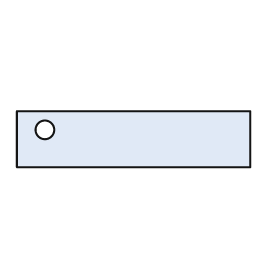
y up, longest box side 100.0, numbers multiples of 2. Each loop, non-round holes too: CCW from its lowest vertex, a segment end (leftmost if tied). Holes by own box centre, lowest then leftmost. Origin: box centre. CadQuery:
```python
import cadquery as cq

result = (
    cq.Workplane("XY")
    .moveTo(-50.0, -12.0)
    .lineTo(50.0, -12.0)
    .lineTo(50.0, 12.0)
    .lineTo(-50.0, 12.0)
    .close()
    .moveTo(-38.0, 4.0)
    .circle(4.0)
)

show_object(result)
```